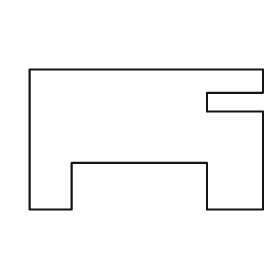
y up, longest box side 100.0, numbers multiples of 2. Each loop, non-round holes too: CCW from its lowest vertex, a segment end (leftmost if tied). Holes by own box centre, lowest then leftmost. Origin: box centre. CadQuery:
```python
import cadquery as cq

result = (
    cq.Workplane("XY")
    .moveTo(-50.0, -30.0)
    .lineTo(-32.0, -30.0)
    .lineTo(-32.0, -10.0)
    .lineTo(26.0, -10.0)
    .lineTo(26.0, -30.0)
    .lineTo(50.0, -30.0)
    .lineTo(50.0, 12.0)
    .lineTo(26.0, 12.0)
    .lineTo(26.0, 20.0)
    .lineTo(50.0, 20.0)
    .lineTo(50.0, 30.0)
    .lineTo(-50.0, 30.0)
    .close()
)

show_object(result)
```